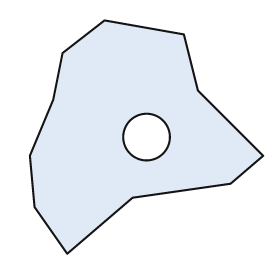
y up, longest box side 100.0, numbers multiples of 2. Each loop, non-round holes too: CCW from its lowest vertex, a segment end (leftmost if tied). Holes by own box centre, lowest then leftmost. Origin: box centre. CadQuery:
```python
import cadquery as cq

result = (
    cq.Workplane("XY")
    .moveTo(-34.0, -50.0)
    .lineTo(-6.0, -26.0)
    .lineTo(36.0, -20.0)
    .lineTo(50.0, -8.0)
    .lineTo(22.0, 20.0)
    .lineTo(16.0, 44.0)
    .lineTo(-18.0, 50.0)
    .lineTo(-36.0, 36.0)
    .lineTo(-40.0, 16.0)
    .lineTo(-50.0, -8.0)
    .lineTo(-48.0, -30.0)
    .close()
    .moveTo(0.0, 0.0)
    .circle(10.0)
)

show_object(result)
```